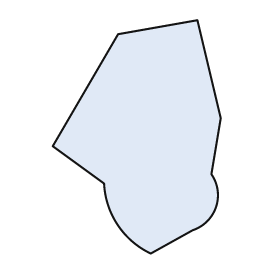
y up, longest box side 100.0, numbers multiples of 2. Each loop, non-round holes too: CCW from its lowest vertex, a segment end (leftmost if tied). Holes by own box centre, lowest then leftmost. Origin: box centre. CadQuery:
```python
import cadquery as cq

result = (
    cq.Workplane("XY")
    .moveTo(6.0, -50.0)
    .lineTo(24.0, -40.0)
    .threePointArc((34.0, -30.0), (32.0, -16.0))
    .lineTo(36.0, 8.0)
    .lineTo(26.0, 50.0)
    .lineTo(-8.0, 44.0)
    .lineTo(-36.0, -4.0)
    .lineTo(-14.0, -20.0)
    .threePointArc((-8.0, -38.0), (6.0, -50.0))
    .close()
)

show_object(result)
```